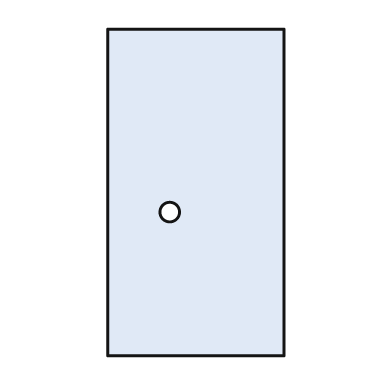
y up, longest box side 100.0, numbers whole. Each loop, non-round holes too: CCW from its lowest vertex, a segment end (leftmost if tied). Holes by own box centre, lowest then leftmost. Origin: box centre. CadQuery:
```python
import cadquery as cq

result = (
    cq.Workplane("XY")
    .moveTo(-27.0, -50.0)
    .lineTo(27.0, -50.0)
    .lineTo(27.0, 50.0)
    .lineTo(-27.0, 50.0)
    .close()
    .moveTo(-8.0, -6.0)
    .circle(3.0)
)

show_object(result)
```